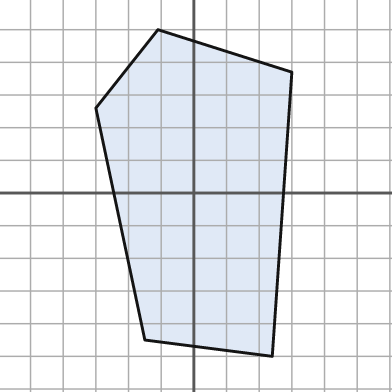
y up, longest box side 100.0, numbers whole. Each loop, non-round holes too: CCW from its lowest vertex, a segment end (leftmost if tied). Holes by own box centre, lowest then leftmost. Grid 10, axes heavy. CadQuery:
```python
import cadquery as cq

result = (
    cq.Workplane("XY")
    .moveTo(24.0, -50.0)
    .lineTo(30.0, 37.0)
    .lineTo(-11.0, 50.0)
    .lineTo(-30.0, 26.0)
    .lineTo(-15.0, -45.0)
    .close()
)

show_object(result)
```